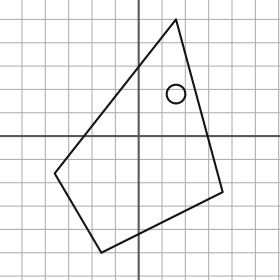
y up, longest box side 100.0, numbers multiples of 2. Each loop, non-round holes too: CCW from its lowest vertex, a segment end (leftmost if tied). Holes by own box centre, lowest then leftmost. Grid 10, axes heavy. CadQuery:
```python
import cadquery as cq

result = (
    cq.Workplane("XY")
    .moveTo(-16.0, -50.0)
    .lineTo(36.0, -24.0)
    .lineTo(16.0, 50.0)
    .lineTo(-36.0, -16.0)
    .close()
    .moveTo(16.0, 18.0)
    .circle(4.0)
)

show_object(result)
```